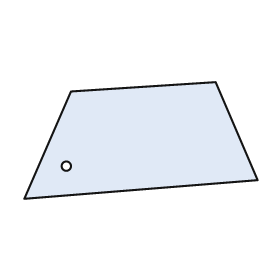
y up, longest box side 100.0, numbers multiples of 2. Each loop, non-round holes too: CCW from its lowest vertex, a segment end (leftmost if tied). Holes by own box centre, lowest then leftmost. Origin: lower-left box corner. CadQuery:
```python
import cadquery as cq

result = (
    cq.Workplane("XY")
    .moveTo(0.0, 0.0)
    .lineTo(100.0, 8.0)
    .lineTo(82.0, 50.0)
    .lineTo(20.0, 46.0)
    .close()
    .moveTo(18.0, 14.0)
    .circle(2.0)
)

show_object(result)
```